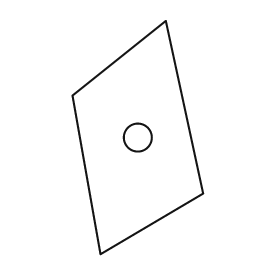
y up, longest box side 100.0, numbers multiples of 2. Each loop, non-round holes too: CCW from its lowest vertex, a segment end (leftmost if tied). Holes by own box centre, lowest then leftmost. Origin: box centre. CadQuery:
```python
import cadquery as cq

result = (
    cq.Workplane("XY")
    .moveTo(-16.0, -50.0)
    .lineTo(28.0, -24.0)
    .lineTo(12.0, 50.0)
    .lineTo(-28.0, 18.0)
    .close()
    .moveTo(0.0, 0.0)
    .circle(6.0)
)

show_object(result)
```